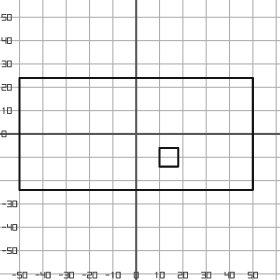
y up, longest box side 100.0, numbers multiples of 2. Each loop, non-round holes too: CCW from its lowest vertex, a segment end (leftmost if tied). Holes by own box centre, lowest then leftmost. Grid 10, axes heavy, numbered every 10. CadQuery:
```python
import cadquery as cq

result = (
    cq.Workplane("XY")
    .moveTo(-50.0, -24.0)
    .lineTo(50.0, -24.0)
    .lineTo(50.0, 24.0)
    .lineTo(-50.0, 24.0)
    .close()
    .moveTo(10.0, -14.0)
    .lineTo(18.0, -14.0)
    .lineTo(18.0, -6.0)
    .lineTo(10.0, -6.0)
    .close()
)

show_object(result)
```